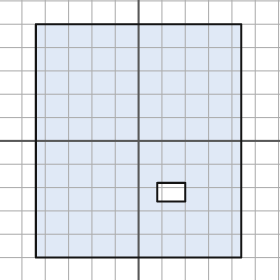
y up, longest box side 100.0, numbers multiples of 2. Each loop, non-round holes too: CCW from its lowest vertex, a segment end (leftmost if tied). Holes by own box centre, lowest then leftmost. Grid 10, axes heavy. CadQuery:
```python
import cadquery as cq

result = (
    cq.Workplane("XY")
    .moveTo(-44.0, -50.0)
    .lineTo(44.0, -50.0)
    .lineTo(44.0, 50.0)
    .lineTo(-44.0, 50.0)
    .close()
    .moveTo(8.0, -26.0)
    .lineTo(20.0, -26.0)
    .lineTo(20.0, -18.0)
    .lineTo(8.0, -18.0)
    .close()
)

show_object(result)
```